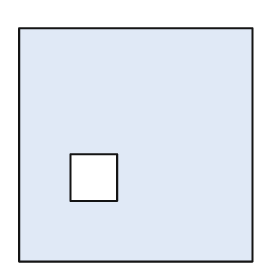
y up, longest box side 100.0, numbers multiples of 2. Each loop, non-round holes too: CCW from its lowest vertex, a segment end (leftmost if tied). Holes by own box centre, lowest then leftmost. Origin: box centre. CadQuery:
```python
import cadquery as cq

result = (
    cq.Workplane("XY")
    .moveTo(-50.0, -50.0)
    .lineTo(50.0, -50.0)
    .lineTo(50.0, 50.0)
    .lineTo(-50.0, 50.0)
    .close()
    .moveTo(-28.0, -24.0)
    .lineTo(-8.0, -24.0)
    .lineTo(-8.0, -4.0)
    .lineTo(-28.0, -4.0)
    .close()
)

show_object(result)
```